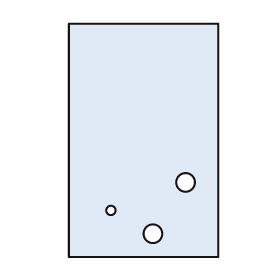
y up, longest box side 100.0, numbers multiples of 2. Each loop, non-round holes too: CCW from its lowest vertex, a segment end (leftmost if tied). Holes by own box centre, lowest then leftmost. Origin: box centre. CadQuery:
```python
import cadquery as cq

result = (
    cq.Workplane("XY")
    .moveTo(-32.0, -50.0)
    .lineTo(32.0, -50.0)
    .lineTo(32.0, 50.0)
    .lineTo(-32.0, 50.0)
    .close()
    .moveTo(4.0, -40.0)
    .circle(4.0)
    .moveTo(-14.0, -30.0)
    .circle(2.0)
    .moveTo(18.0, -18.0)
    .circle(4.0)
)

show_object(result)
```